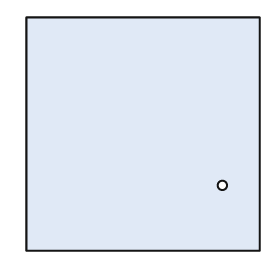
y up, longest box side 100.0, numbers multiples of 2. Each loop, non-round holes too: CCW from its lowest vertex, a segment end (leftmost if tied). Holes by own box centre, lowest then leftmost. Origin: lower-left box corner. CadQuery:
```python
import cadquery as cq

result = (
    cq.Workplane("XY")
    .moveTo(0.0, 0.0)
    .lineTo(100.0, 0.0)
    .lineTo(100.0, 100.0)
    .lineTo(0.0, 100.0)
    .close()
    .moveTo(84.0, 28.0)
    .circle(2.0)
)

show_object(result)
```